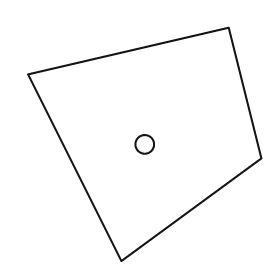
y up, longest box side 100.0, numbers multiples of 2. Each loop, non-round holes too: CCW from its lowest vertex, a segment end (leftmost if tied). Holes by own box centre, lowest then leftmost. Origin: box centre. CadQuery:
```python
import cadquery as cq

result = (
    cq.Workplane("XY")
    .moveTo(-10.0, -50.0)
    .lineTo(50.0, -6.0)
    .lineTo(36.0, 50.0)
    .lineTo(-50.0, 30.0)
    .close()
    .moveTo(0.0, 0.0)
    .circle(4.0)
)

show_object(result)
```